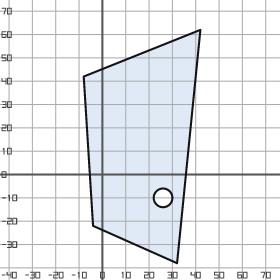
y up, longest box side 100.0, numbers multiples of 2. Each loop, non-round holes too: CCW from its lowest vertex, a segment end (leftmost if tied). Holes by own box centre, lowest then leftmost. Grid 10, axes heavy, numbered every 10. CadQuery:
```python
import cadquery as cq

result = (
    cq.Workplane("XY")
    .moveTo(32.0, -38.0)
    .lineTo(42.0, 62.0)
    .lineTo(-8.0, 42.0)
    .lineTo(-4.0, -22.0)
    .close()
    .moveTo(26.0, -10.0)
    .circle(4.0)
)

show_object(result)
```